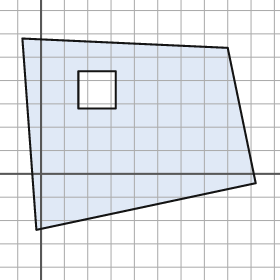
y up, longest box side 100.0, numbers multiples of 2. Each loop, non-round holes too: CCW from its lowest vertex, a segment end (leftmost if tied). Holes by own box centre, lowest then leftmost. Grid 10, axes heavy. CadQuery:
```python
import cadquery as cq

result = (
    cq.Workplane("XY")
    .moveTo(-2.0, -24.0)
    .lineTo(92.0, -4.0)
    .lineTo(80.0, 54.0)
    .lineTo(-8.0, 58.0)
    .close()
    .moveTo(16.0, 28.0)
    .lineTo(32.0, 28.0)
    .lineTo(32.0, 44.0)
    .lineTo(16.0, 44.0)
    .close()
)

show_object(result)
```